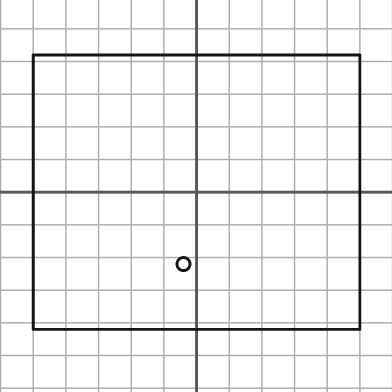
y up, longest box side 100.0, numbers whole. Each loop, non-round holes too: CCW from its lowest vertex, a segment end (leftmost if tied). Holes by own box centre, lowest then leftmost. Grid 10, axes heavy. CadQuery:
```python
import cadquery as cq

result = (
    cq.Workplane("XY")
    .moveTo(-50.0, -42.0)
    .lineTo(50.0, -42.0)
    .lineTo(50.0, 42.0)
    .lineTo(-50.0, 42.0)
    .close()
    .moveTo(-4.0, -22.0)
    .circle(2.0)
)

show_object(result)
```